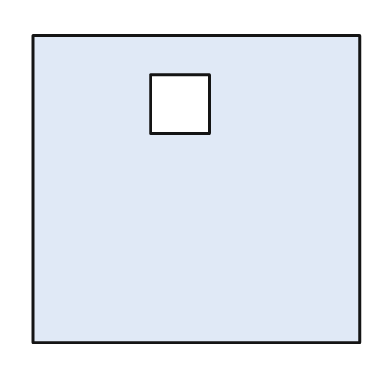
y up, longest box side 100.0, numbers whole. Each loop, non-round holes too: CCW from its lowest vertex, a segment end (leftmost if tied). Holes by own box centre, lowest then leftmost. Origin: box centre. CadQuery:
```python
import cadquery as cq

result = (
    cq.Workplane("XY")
    .moveTo(-50.0, -47.0)
    .lineTo(50.0, -47.0)
    .lineTo(50.0, 47.0)
    .lineTo(-50.0, 47.0)
    .close()
    .moveTo(-14.0, 17.0)
    .lineTo(4.0, 17.0)
    .lineTo(4.0, 35.0)
    .lineTo(-14.0, 35.0)
    .close()
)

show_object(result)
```